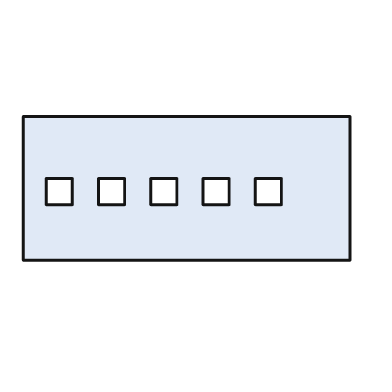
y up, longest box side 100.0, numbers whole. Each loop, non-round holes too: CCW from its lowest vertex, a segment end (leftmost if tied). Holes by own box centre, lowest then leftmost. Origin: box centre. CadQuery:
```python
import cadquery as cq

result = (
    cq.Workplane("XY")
    .moveTo(-50.0, -22.0)
    .lineTo(50.0, -22.0)
    .lineTo(50.0, 22.0)
    .lineTo(-50.0, 22.0)
    .close()
    .moveTo(-43.0, -5.0)
    .lineTo(-35.0, -5.0)
    .lineTo(-35.0, 3.0)
    .lineTo(-43.0, 3.0)
    .close()
    .moveTo(-27.0, -5.0)
    .lineTo(-19.0, -5.0)
    .lineTo(-19.0, 3.0)
    .lineTo(-27.0, 3.0)
    .close()
    .moveTo(-11.0, -5.0)
    .lineTo(-3.0, -5.0)
    .lineTo(-3.0, 3.0)
    .lineTo(-11.0, 3.0)
    .close()
    .moveTo(5.0, -5.0)
    .lineTo(13.0, -5.0)
    .lineTo(13.0, 3.0)
    .lineTo(5.0, 3.0)
    .close()
    .moveTo(21.0, -5.0)
    .lineTo(29.0, -5.0)
    .lineTo(29.0, 3.0)
    .lineTo(21.0, 3.0)
    .close()
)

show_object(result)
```